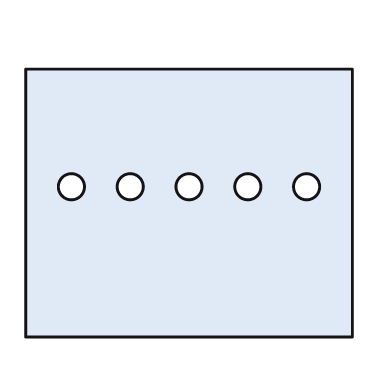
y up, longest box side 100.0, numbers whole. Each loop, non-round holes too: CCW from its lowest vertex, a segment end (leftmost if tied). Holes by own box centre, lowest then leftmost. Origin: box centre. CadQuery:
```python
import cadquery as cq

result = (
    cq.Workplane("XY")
    .moveTo(-50.0, -41.0)
    .lineTo(50.0, -41.0)
    .lineTo(50.0, 41.0)
    .lineTo(-50.0, 41.0)
    .close()
    .moveTo(-36.0, 5.0)
    .circle(4.0)
    .moveTo(-18.0, 5.0)
    .circle(4.0)
    .moveTo(0.0, 5.0)
    .circle(4.0)
    .moveTo(18.0, 5.0)
    .circle(4.0)
    .moveTo(36.0, 5.0)
    .circle(4.0)
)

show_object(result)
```